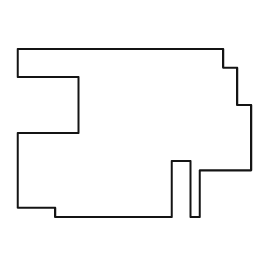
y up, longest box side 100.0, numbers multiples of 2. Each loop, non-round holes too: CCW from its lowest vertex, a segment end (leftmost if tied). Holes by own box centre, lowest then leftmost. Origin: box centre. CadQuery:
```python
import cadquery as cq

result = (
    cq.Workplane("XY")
    .moveTo(-34.0, -36.0)
    .lineTo(16.0, -36.0)
    .lineTo(16.0, -12.0)
    .lineTo(24.0, -12.0)
    .lineTo(24.0, -36.0)
    .lineTo(28.0, -36.0)
    .lineTo(28.0, -16.0)
    .lineTo(50.0, -16.0)
    .lineTo(50.0, 12.0)
    .lineTo(44.0, 12.0)
    .lineTo(44.0, 28.0)
    .lineTo(38.0, 28.0)
    .lineTo(38.0, 36.0)
    .lineTo(-50.0, 36.0)
    .lineTo(-50.0, 24.0)
    .lineTo(-24.0, 24.0)
    .lineTo(-24.0, 0.0)
    .lineTo(-50.0, 0.0)
    .lineTo(-50.0, -32.0)
    .lineTo(-34.0, -32.0)
    .close()
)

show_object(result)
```